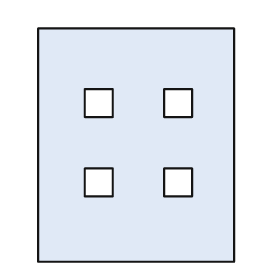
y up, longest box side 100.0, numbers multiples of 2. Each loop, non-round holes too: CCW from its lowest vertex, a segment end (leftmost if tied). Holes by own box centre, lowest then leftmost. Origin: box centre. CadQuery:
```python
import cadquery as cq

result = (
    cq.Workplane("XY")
    .moveTo(-42.0, -50.0)
    .lineTo(42.0, -50.0)
    .lineTo(42.0, 50.0)
    .lineTo(-42.0, 50.0)
    .close()
    .moveTo(-22.0, -22.0)
    .lineTo(-10.0, -22.0)
    .lineTo(-10.0, -10.0)
    .lineTo(-22.0, -10.0)
    .close()
    .moveTo(12.0, -22.0)
    .lineTo(24.0, -22.0)
    .lineTo(24.0, -10.0)
    .lineTo(12.0, -10.0)
    .close()
    .moveTo(-22.0, 12.0)
    .lineTo(-10.0, 12.0)
    .lineTo(-10.0, 24.0)
    .lineTo(-22.0, 24.0)
    .close()
    .moveTo(12.0, 12.0)
    .lineTo(24.0, 12.0)
    .lineTo(24.0, 24.0)
    .lineTo(12.0, 24.0)
    .close()
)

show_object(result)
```